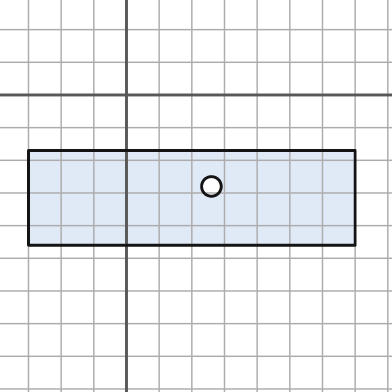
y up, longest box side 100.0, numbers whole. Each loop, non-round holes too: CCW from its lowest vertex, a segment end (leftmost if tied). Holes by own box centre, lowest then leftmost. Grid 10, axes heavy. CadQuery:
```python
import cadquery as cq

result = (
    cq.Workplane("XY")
    .moveTo(-30.0, -46.0)
    .lineTo(70.0, -46.0)
    .lineTo(70.0, -17.0)
    .lineTo(-30.0, -17.0)
    .close()
    .moveTo(26.0, -28.0)
    .circle(3.0)
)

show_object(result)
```